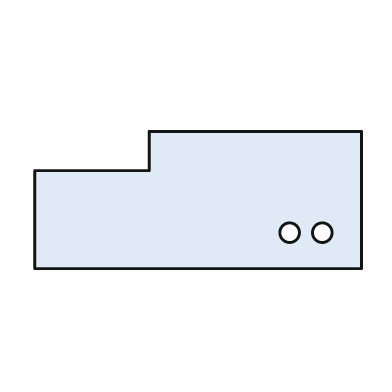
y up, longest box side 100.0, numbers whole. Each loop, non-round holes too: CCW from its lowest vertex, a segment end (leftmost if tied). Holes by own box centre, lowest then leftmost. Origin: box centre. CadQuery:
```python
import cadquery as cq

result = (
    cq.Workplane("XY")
    .moveTo(-50.0, -21.0)
    .lineTo(50.0, -21.0)
    .lineTo(50.0, 21.0)
    .lineTo(-15.0, 21.0)
    .lineTo(-15.0, 9.0)
    .lineTo(-50.0, 9.0)
    .close()
    .moveTo(28.0, -10.0)
    .circle(3.0)
    .moveTo(38.0, -10.0)
    .circle(3.0)
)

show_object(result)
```